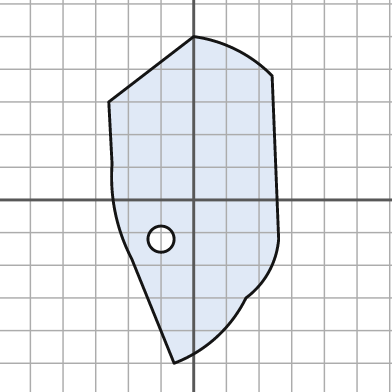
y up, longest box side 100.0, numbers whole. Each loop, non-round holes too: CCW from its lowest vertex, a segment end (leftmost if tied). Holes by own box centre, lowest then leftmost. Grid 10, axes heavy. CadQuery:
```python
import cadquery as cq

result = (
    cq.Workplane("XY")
    .moveTo(-6.0, -50.0)
    .threePointArc((7.0, -42.0), (16.0, -30.0))
    .threePointArc((23.0, -22.0), (26.0, -12.0))
    .lineTo(24.0, 38.0)
    .threePointArc((13.0, 46.0), (0.0, 50.0))
    .lineTo(-26.0, 30.0)
    .lineTo(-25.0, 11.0)
    .threePointArc((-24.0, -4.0), (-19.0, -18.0))
    .close()
    .moveTo(-10.0, -12.0)
    .circle(4.0)
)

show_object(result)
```